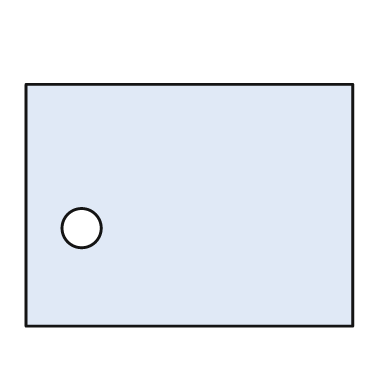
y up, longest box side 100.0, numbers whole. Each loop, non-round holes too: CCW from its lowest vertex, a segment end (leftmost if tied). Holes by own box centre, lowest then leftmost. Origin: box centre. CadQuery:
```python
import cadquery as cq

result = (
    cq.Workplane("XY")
    .moveTo(-50.0, -37.0)
    .lineTo(50.0, -37.0)
    .lineTo(50.0, 37.0)
    .lineTo(-50.0, 37.0)
    .close()
    .moveTo(-33.0, -7.0)
    .circle(6.0)
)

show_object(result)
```